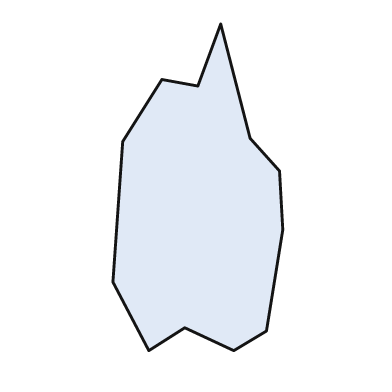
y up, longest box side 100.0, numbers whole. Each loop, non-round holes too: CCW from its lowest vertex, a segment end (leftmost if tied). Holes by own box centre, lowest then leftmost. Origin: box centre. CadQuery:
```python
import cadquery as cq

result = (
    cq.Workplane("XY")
    .moveTo(-15.0, -50.0)
    .lineTo(-4.0, -43.0)
    .lineTo(11.0, -50.0)
    .lineTo(21.0, -44.0)
    .lineTo(26.0, -13.0)
    .lineTo(25.0, 5.0)
    .lineTo(16.0, 15.0)
    .lineTo(7.0, 50.0)
    .lineTo(0.0, 31.0)
    .lineTo(-11.0, 33.0)
    .lineTo(-23.0, 14.0)
    .lineTo(-26.0, -29.0)
    .close()
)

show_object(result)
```